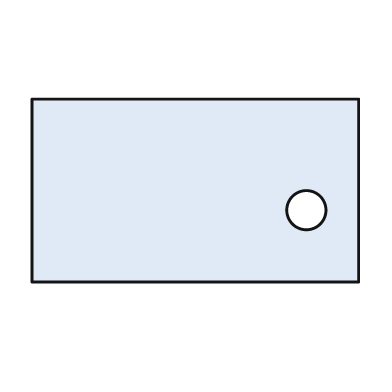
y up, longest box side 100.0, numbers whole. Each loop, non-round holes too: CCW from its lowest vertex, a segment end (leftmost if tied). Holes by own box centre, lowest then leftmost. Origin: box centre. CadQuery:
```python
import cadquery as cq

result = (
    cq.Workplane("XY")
    .moveTo(-50.0, -28.0)
    .lineTo(50.0, -28.0)
    .lineTo(50.0, 28.0)
    .lineTo(-50.0, 28.0)
    .close()
    .moveTo(34.0, -6.0)
    .circle(6.0)
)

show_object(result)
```